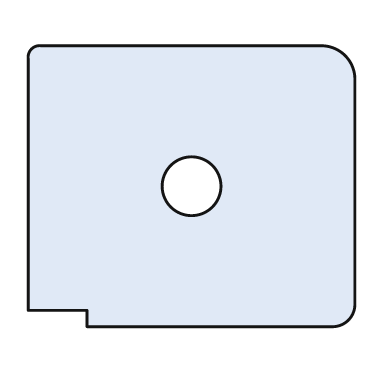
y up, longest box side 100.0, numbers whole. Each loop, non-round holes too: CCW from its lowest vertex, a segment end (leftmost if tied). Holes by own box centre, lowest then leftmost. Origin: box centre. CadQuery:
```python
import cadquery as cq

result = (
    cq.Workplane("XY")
    .moveTo(-32.0, -43.0)
    .lineTo(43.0, -43.0)
    .threePointArc((48.0, -41.0), (50.0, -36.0))
    .lineTo(50.0, 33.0)
    .threePointArc((47.0, 40.0), (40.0, 43.0))
    .lineTo(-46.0, 43.0)
    .threePointArc((-49.0, 42.0), (-50.0, 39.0))
    .lineTo(-50.0, -38.0)
    .lineTo(-32.0, -38.0)
    .close()
    .moveTo(0.0, 0.0)
    .circle(9.0)
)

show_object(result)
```